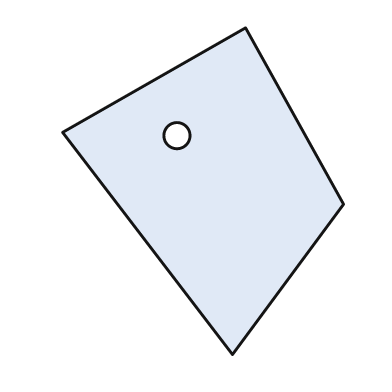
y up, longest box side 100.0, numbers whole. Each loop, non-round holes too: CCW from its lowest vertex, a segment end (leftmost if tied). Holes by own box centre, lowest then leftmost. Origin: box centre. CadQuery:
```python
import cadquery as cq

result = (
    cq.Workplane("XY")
    .moveTo(9.0, -50.0)
    .lineTo(43.0, -4.0)
    .lineTo(13.0, 50.0)
    .lineTo(-43.0, 18.0)
    .close()
    .moveTo(-8.0, 17.0)
    .circle(4.0)
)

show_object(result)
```